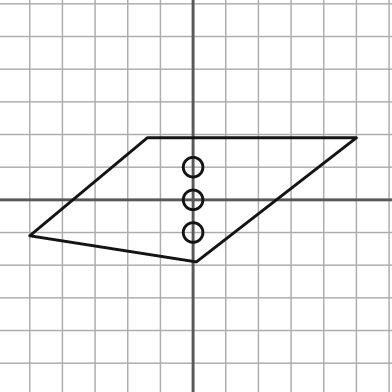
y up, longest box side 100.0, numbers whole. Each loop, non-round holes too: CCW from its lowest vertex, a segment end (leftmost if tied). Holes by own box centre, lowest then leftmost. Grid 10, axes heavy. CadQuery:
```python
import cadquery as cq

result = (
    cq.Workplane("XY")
    .moveTo(1.0, -19.0)
    .lineTo(50.0, 19.0)
    .lineTo(-14.0, 19.0)
    .lineTo(-50.0, -11.0)
    .close()
    .moveTo(0.0, -10.0)
    .circle(3.0)
    .moveTo(0.0, 0.0)
    .circle(3.0)
    .moveTo(0.0, 10.0)
    .circle(3.0)
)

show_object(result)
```